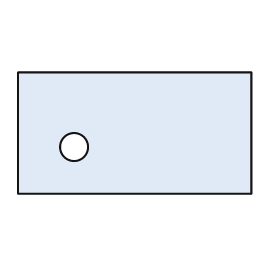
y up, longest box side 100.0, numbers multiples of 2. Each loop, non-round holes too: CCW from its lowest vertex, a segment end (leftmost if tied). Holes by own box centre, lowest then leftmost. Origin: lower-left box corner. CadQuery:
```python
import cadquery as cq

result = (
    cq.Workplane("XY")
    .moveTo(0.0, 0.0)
    .lineTo(100.0, 0.0)
    .lineTo(100.0, 52.0)
    .lineTo(0.0, 52.0)
    .close()
    .moveTo(24.0, 20.0)
    .circle(6.0)
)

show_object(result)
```